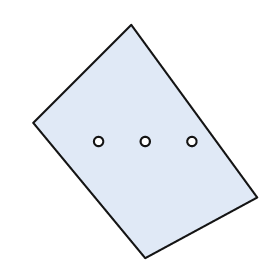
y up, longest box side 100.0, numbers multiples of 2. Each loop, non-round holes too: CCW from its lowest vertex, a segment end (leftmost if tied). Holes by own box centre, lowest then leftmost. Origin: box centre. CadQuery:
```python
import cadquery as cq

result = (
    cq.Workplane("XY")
    .moveTo(0.0, -50.0)
    .lineTo(48.0, -24.0)
    .lineTo(-6.0, 50.0)
    .lineTo(-48.0, 8.0)
    .close()
    .moveTo(-20.0, 0.0)
    .circle(2.0)
    .moveTo(0.0, 0.0)
    .circle(2.0)
    .moveTo(20.0, 0.0)
    .circle(2.0)
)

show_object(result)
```